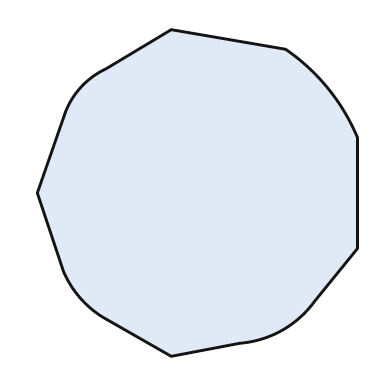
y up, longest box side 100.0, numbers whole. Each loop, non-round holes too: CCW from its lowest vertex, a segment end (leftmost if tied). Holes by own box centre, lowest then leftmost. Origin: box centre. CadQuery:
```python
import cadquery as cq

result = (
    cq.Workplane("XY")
    .moveTo(-8.0, -50.0)
    .lineTo(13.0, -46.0)
    .threePointArc((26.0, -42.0), (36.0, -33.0))
    .lineTo(49.0, -17.0)
    .lineTo(49.0, 17.0)
    .threePointArc((40.0, 32.0), (27.0, 44.0))
    .lineTo(-8.0, 50.0)
    .lineTo(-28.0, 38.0)
    .threePointArc((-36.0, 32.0), (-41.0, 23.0))
    .lineTo(-49.0, 0.0)
    .lineTo(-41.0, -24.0)
    .threePointArc((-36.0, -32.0), (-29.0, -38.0))
    .close()
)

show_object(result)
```